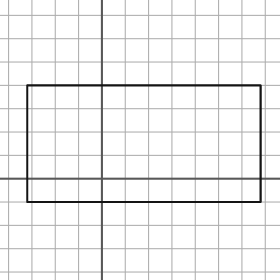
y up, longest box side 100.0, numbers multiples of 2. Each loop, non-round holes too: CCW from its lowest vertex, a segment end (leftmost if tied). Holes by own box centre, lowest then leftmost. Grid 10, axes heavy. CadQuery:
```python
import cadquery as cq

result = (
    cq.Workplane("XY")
    .moveTo(-32.0, -10.0)
    .lineTo(68.0, -10.0)
    .lineTo(68.0, 40.0)
    .lineTo(-32.0, 40.0)
    .close()
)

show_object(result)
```